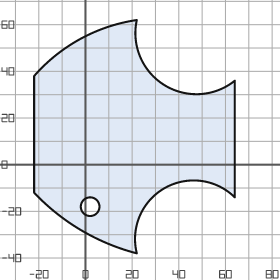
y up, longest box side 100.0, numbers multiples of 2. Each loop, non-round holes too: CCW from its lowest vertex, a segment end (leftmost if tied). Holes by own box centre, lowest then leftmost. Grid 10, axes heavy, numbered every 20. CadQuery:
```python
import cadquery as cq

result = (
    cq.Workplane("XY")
    .moveTo(22.0, -38.0)
    .threePointArc((34.0, -10.0), (64.0, -14.0))
    .lineTo(64.0, 36.0)
    .threePointArc((34.0, 34.0), (22.0, 62.0))
    .threePointArc((-2.0, 54.0), (-22.0, 38.0))
    .lineTo(-22.0, -12.0)
    .threePointArc((-2.0, -28.0), (22.0, -38.0))
    .close()
    .moveTo(2.0, -18.0)
    .circle(4.0)
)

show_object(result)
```